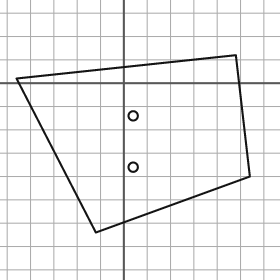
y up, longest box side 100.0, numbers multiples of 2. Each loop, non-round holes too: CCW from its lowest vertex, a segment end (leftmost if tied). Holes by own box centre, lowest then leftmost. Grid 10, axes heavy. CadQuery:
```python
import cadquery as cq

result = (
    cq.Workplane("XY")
    .moveTo(-12.0, -64.0)
    .lineTo(54.0, -40.0)
    .lineTo(48.0, 12.0)
    .lineTo(-46.0, 2.0)
    .close()
    .moveTo(4.0, -36.0)
    .circle(2.0)
    .moveTo(4.0, -14.0)
    .circle(2.0)
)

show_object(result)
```